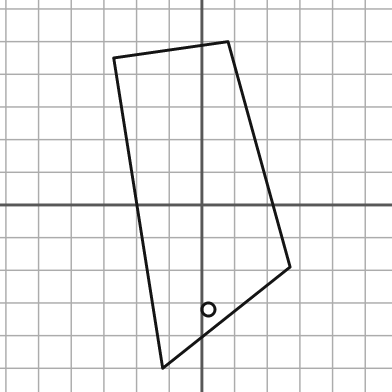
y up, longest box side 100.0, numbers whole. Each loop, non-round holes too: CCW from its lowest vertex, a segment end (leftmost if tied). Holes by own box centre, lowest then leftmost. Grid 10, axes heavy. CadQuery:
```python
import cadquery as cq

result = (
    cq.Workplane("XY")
    .moveTo(-12.0, -50.0)
    .lineTo(27.0, -19.0)
    .lineTo(8.0, 50.0)
    .lineTo(-27.0, 45.0)
    .close()
    .moveTo(2.0, -32.0)
    .circle(2.0)
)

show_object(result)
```